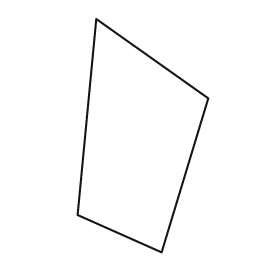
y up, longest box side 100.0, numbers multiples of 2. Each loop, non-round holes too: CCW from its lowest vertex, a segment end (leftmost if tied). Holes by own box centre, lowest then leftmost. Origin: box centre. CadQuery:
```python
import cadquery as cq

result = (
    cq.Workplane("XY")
    .moveTo(8.0, -50.0)
    .lineTo(28.0, 16.0)
    .lineTo(-20.0, 50.0)
    .lineTo(-28.0, -34.0)
    .close()
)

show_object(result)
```